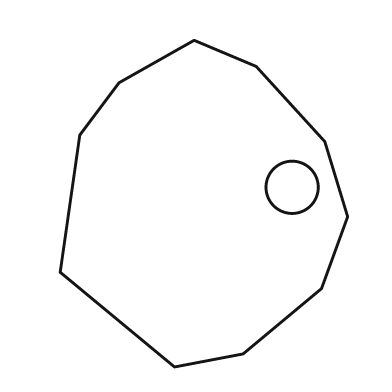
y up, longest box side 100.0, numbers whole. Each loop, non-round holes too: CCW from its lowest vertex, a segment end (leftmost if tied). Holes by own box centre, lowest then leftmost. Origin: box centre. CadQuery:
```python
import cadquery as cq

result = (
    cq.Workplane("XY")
    .moveTo(-9.0, -50.0)
    .lineTo(12.0, -46.0)
    .lineTo(36.0, -26.0)
    .lineTo(44.0, -4.0)
    .lineTo(37.0, 19.0)
    .lineTo(16.0, 42.0)
    .lineTo(-3.0, 50.0)
    .lineTo(-26.0, 37.0)
    .lineTo(-38.0, 21.0)
    .lineTo(-44.0, -21.0)
    .close()
    .moveTo(27.0, 5.0)
    .circle(8.0)
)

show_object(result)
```